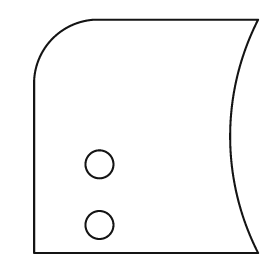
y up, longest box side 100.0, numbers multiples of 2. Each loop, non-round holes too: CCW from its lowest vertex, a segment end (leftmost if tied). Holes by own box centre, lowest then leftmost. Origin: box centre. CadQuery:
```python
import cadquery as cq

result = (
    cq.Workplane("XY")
    .moveTo(-48.0, -50.0)
    .lineTo(48.0, -50.0)
    .threePointArc((36.0, 0.0), (48.0, 50.0))
    .lineTo(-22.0, 50.0)
    .threePointArc((-40.0, 42.0), (-48.0, 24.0))
    .close()
    .moveTo(-20.0, -38.0)
    .circle(6.0)
    .moveTo(-20.0, -12.0)
    .circle(6.0)
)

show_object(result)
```